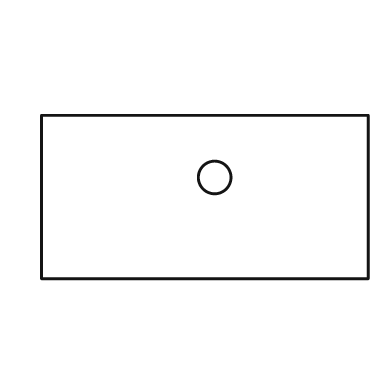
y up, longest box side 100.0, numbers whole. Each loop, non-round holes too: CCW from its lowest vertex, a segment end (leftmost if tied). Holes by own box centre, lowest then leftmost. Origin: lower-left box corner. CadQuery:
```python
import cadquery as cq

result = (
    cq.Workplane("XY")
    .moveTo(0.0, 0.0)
    .lineTo(100.0, 0.0)
    .lineTo(100.0, 50.0)
    .lineTo(0.0, 50.0)
    .close()
    .moveTo(53.0, 31.0)
    .circle(5.0)
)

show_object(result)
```